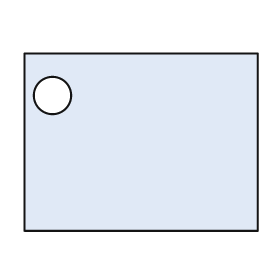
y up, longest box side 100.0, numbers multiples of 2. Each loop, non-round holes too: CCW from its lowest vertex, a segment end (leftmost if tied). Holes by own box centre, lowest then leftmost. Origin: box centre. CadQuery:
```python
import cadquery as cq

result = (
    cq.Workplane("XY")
    .moveTo(-50.0, -38.0)
    .lineTo(50.0, -38.0)
    .lineTo(50.0, 38.0)
    .lineTo(-50.0, 38.0)
    .close()
    .moveTo(-38.0, 20.0)
    .circle(8.0)
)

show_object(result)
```